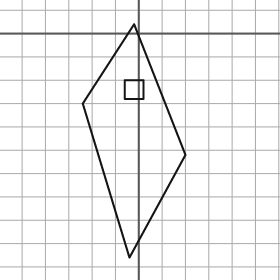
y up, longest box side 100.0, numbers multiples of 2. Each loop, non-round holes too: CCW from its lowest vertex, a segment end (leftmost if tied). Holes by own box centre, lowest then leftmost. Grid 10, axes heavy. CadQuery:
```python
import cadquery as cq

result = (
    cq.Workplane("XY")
    .moveTo(-4.0, -96.0)
    .lineTo(20.0, -52.0)
    .lineTo(-2.0, 4.0)
    .lineTo(-24.0, -30.0)
    .close()
    .moveTo(-6.0, -28.0)
    .lineTo(2.0, -28.0)
    .lineTo(2.0, -20.0)
    .lineTo(-6.0, -20.0)
    .close()
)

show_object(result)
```